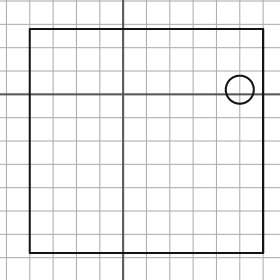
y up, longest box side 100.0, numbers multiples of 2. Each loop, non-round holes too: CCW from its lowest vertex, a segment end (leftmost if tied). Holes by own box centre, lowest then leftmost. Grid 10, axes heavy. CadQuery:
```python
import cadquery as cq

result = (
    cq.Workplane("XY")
    .moveTo(-40.0, -68.0)
    .lineTo(60.0, -68.0)
    .lineTo(60.0, 28.0)
    .lineTo(-40.0, 28.0)
    .close()
    .moveTo(50.0, 2.0)
    .circle(6.0)
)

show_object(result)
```